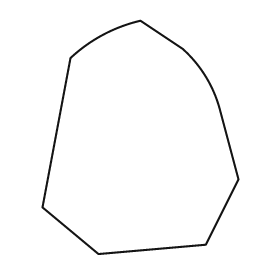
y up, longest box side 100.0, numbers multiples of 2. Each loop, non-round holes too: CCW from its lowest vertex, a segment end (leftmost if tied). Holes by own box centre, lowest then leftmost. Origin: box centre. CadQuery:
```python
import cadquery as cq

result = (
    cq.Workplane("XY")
    .moveTo(-18.0, -50.0)
    .lineTo(28.0, -46.0)
    .lineTo(42.0, -18.0)
    .lineTo(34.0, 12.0)
    .threePointArc((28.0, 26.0), (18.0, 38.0))
    .lineTo(0.0, 50.0)
    .threePointArc((-16.0, 44.0), (-30.0, 34.0))
    .lineTo(-42.0, -30.0)
    .close()
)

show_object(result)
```